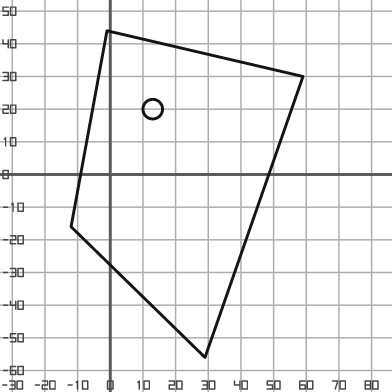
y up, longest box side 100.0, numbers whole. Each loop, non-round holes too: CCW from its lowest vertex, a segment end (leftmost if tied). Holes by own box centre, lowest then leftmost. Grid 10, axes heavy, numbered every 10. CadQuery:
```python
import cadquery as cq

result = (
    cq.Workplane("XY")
    .moveTo(29.0, -56.0)
    .lineTo(59.0, 30.0)
    .lineTo(-1.0, 44.0)
    .lineTo(-12.0, -16.0)
    .close()
    .moveTo(13.0, 20.0)
    .circle(3.0)
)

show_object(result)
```